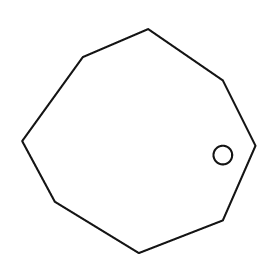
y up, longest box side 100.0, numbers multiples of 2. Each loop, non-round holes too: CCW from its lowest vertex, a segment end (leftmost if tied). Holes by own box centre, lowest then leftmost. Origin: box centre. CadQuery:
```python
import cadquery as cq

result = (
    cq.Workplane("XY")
    .moveTo(0.0, -48.0)
    .lineTo(36.0, -34.0)
    .lineTo(50.0, -2.0)
    .lineTo(36.0, 26.0)
    .lineTo(4.0, 48.0)
    .lineTo(-24.0, 36.0)
    .lineTo(-50.0, 0.0)
    .lineTo(-36.0, -26.0)
    .close()
    .moveTo(36.0, -6.0)
    .circle(4.0)
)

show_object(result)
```